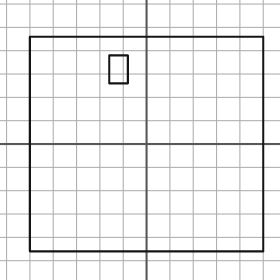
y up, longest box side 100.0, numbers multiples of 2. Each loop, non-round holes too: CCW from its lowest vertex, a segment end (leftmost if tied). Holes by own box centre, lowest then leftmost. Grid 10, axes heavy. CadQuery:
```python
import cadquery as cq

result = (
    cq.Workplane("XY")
    .moveTo(-50.0, -46.0)
    .lineTo(50.0, -46.0)
    .lineTo(50.0, 46.0)
    .lineTo(-50.0, 46.0)
    .close()
    .moveTo(-16.0, 26.0)
    .lineTo(-8.0, 26.0)
    .lineTo(-8.0, 38.0)
    .lineTo(-16.0, 38.0)
    .close()
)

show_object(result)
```